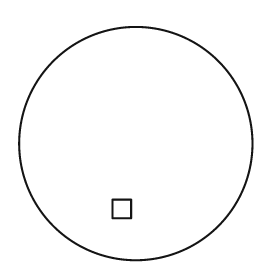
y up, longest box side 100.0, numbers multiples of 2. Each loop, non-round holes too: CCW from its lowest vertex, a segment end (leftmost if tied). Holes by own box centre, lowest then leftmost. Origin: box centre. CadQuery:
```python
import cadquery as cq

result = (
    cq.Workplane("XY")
    .moveTo(0.0, 0.0)
    .circle(50.0)
    .moveTo(-10.0, -32.0)
    .lineTo(-2.0, -32.0)
    .lineTo(-2.0, -24.0)
    .lineTo(-10.0, -24.0)
    .close()
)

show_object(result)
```